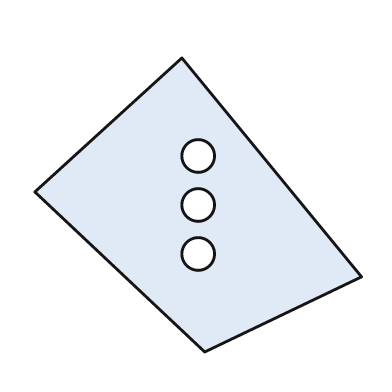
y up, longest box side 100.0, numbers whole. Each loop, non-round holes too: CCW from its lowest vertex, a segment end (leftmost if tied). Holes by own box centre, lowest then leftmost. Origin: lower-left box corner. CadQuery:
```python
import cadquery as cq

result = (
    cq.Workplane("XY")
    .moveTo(52.0, 0.0)
    .lineTo(100.0, 23.0)
    .lineTo(45.0, 90.0)
    .lineTo(0.0, 49.0)
    .close()
    .moveTo(50.0, 30.0)
    .circle(5.0)
    .moveTo(50.0, 45.0)
    .circle(5.0)
    .moveTo(50.0, 60.0)
    .circle(5.0)
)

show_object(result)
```